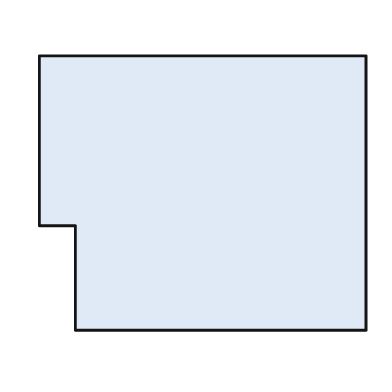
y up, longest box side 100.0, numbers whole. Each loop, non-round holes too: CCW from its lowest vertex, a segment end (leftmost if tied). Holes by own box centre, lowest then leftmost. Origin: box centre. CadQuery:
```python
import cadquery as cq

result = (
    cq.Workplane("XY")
    .moveTo(-39.0, -42.0)
    .lineTo(50.0, -42.0)
    .lineTo(50.0, 42.0)
    .lineTo(-50.0, 42.0)
    .lineTo(-50.0, -10.0)
    .lineTo(-39.0, -10.0)
    .close()
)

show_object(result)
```